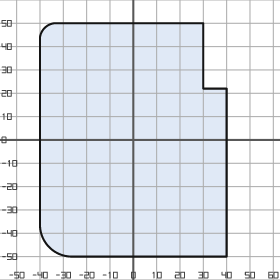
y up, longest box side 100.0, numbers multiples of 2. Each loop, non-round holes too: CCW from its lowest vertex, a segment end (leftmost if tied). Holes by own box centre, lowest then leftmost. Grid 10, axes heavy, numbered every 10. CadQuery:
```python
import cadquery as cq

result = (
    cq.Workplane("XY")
    .moveTo(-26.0, -50.0)
    .lineTo(40.0, -50.0)
    .lineTo(40.0, 22.0)
    .lineTo(30.0, 22.0)
    .lineTo(30.0, 50.0)
    .lineTo(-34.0, 50.0)
    .threePointArc((-38.0, 48.0), (-40.0, 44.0))
    .lineTo(-40.0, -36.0)
    .threePointArc((-36.0, -46.0), (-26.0, -50.0))
    .close()
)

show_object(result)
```